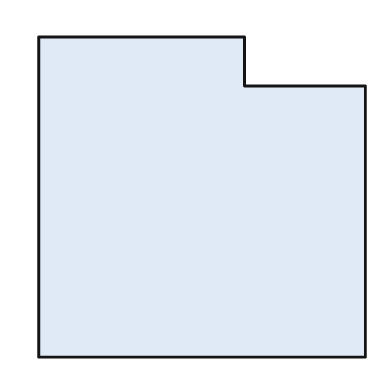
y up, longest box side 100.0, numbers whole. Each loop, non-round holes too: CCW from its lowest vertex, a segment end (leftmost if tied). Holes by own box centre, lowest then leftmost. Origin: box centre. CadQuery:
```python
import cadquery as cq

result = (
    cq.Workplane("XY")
    .moveTo(-50.0, -49.0)
    .lineTo(50.0, -49.0)
    .lineTo(50.0, 34.0)
    .lineTo(13.0, 34.0)
    .lineTo(13.0, 49.0)
    .lineTo(-50.0, 49.0)
    .close()
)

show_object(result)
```